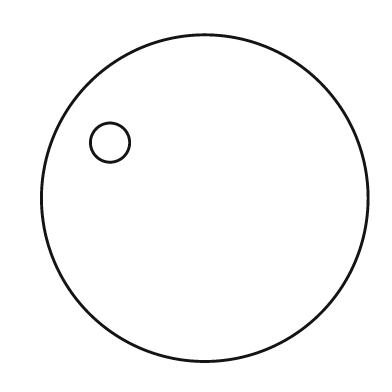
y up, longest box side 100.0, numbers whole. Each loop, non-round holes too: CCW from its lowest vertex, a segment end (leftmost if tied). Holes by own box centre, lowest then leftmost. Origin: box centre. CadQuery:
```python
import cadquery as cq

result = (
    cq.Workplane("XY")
    .moveTo(0.0, 0.0)
    .circle(50.0)
    .moveTo(-29.0, 17.0)
    .circle(6.0)
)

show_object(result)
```